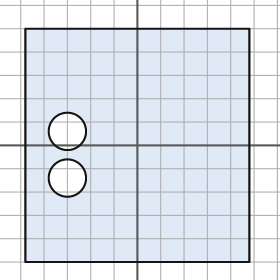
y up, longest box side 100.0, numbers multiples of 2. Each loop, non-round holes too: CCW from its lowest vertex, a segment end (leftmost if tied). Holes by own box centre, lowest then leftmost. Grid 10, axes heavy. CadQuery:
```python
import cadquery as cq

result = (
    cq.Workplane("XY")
    .moveTo(-48.0, -50.0)
    .lineTo(48.0, -50.0)
    .lineTo(48.0, 50.0)
    .lineTo(-48.0, 50.0)
    .close()
    .moveTo(-30.0, -14.0)
    .circle(8.0)
    .moveTo(-30.0, 6.0)
    .circle(8.0)
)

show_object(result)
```